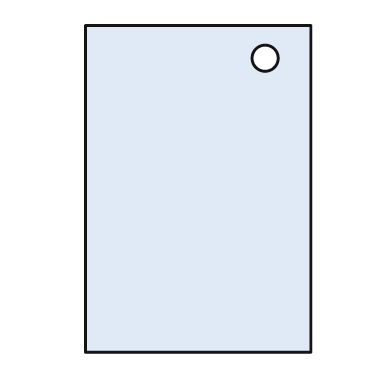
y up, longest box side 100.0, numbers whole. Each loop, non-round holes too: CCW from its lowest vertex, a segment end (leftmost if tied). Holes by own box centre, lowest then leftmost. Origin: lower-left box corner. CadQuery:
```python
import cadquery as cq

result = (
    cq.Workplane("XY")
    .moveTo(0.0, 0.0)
    .lineTo(69.0, 0.0)
    .lineTo(69.0, 100.0)
    .lineTo(0.0, 100.0)
    .close()
    .moveTo(55.0, 90.0)
    .circle(4.0)
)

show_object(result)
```